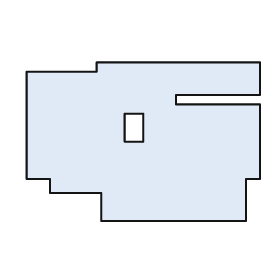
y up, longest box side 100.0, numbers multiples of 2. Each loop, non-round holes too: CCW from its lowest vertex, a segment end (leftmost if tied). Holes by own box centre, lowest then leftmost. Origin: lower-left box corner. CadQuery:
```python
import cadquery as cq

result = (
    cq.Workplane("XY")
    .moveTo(32.0, 0.0)
    .lineTo(94.0, 0.0)
    .lineTo(94.0, 18.0)
    .lineTo(100.0, 18.0)
    .lineTo(100.0, 50.0)
    .lineTo(64.0, 50.0)
    .lineTo(64.0, 54.0)
    .lineTo(100.0, 54.0)
    .lineTo(100.0, 68.0)
    .lineTo(30.0, 68.0)
    .lineTo(30.0, 64.0)
    .lineTo(0.0, 64.0)
    .lineTo(0.0, 18.0)
    .lineTo(10.0, 18.0)
    .lineTo(10.0, 12.0)
    .lineTo(32.0, 12.0)
    .close()
    .moveTo(42.0, 34.0)
    .lineTo(50.0, 34.0)
    .lineTo(50.0, 46.0)
    .lineTo(42.0, 46.0)
    .close()
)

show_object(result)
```